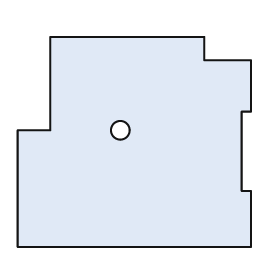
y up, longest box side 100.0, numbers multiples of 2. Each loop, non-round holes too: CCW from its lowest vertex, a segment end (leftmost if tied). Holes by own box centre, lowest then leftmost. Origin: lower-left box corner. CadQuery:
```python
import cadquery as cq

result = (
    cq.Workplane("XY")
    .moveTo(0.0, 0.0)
    .lineTo(100.0, 0.0)
    .lineTo(100.0, 24.0)
    .lineTo(96.0, 24.0)
    .lineTo(96.0, 58.0)
    .lineTo(100.0, 58.0)
    .lineTo(100.0, 80.0)
    .lineTo(80.0, 80.0)
    .lineTo(80.0, 90.0)
    .lineTo(14.0, 90.0)
    .lineTo(14.0, 50.0)
    .lineTo(0.0, 50.0)
    .close()
    .moveTo(44.0, 50.0)
    .circle(4.0)
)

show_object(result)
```